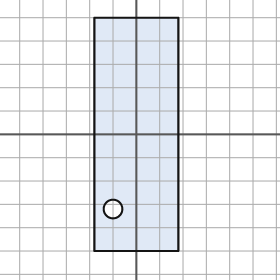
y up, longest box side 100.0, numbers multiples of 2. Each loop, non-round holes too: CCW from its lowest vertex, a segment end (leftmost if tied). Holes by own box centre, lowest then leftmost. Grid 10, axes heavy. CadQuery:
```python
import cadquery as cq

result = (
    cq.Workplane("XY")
    .moveTo(-18.0, -50.0)
    .lineTo(18.0, -50.0)
    .lineTo(18.0, 50.0)
    .lineTo(-18.0, 50.0)
    .close()
    .moveTo(-10.0, -32.0)
    .circle(4.0)
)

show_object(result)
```